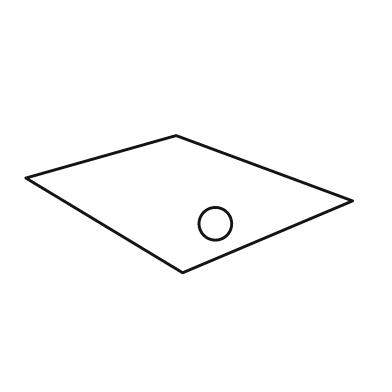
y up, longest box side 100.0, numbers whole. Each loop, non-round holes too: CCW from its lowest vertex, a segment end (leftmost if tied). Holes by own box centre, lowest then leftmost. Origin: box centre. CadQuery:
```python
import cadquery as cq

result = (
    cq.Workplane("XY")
    .moveTo(-2.0, -21.0)
    .lineTo(50.0, 1.0)
    .lineTo(-4.0, 21.0)
    .lineTo(-50.0, 8.0)
    .close()
    .moveTo(8.0, -6.0)
    .circle(5.0)
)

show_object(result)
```